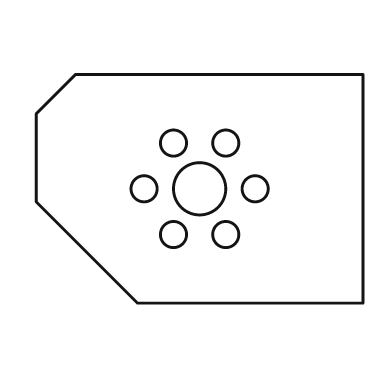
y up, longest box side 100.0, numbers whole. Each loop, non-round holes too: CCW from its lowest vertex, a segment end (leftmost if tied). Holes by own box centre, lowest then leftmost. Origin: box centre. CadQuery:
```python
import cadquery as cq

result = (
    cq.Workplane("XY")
    .moveTo(-19.0, -35.0)
    .lineTo(50.0, -35.0)
    .lineTo(50.0, 35.0)
    .lineTo(-38.0, 35.0)
    .lineTo(-50.0, 23.0)
    .lineTo(-50.0, -4.0)
    .close()
    .moveTo(-8.0, -14.0)
    .circle(4.0)
    .moveTo(8.0, -14.0)
    .circle(4.0)
    .moveTo(-17.0, 0.0)
    .circle(4.0)
    .moveTo(0.0, 0.0)
    .circle(8.0)
    .moveTo(17.0, 0.0)
    .circle(4.0)
    .moveTo(-8.0, 14.0)
    .circle(4.0)
    .moveTo(8.0, 14.0)
    .circle(4.0)
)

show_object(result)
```